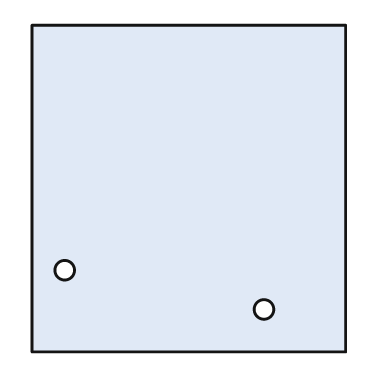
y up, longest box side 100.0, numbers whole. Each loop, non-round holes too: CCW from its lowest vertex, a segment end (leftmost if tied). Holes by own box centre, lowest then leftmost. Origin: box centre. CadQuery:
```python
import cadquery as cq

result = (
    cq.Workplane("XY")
    .moveTo(-48.0, -50.0)
    .lineTo(48.0, -50.0)
    .lineTo(48.0, 50.0)
    .lineTo(-48.0, 50.0)
    .close()
    .moveTo(23.0, -37.0)
    .circle(3.0)
    .moveTo(-38.0, -25.0)
    .circle(3.0)
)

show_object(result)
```